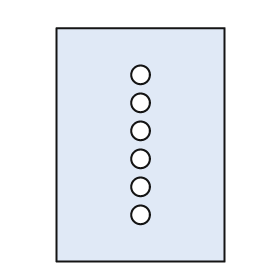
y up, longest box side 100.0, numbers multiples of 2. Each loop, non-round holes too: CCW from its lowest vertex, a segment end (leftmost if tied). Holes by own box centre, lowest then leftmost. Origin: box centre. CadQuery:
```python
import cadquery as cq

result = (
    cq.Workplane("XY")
    .moveTo(-36.0, -50.0)
    .lineTo(36.0, -50.0)
    .lineTo(36.0, 50.0)
    .lineTo(-36.0, 50.0)
    .close()
    .moveTo(0.0, -30.0)
    .circle(4.0)
    .moveTo(0.0, -18.0)
    .circle(4.0)
    .moveTo(0.0, -6.0)
    .circle(4.0)
    .moveTo(0.0, 6.0)
    .circle(4.0)
    .moveTo(0.0, 18.0)
    .circle(4.0)
    .moveTo(0.0, 30.0)
    .circle(4.0)
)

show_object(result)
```